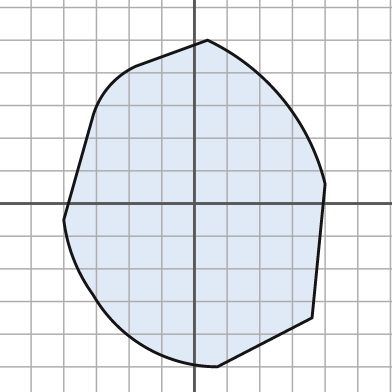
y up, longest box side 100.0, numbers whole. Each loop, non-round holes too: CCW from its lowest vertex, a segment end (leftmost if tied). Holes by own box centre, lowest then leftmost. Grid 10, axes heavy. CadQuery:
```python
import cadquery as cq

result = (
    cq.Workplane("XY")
    .moveTo(7.0, -50.0)
    .lineTo(36.0, -35.0)
    .lineTo(40.0, 6.0)
    .threePointArc((27.0, 32.0), (4.0, 50.0))
    .lineTo(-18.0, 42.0)
    .threePointArc((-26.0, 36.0), (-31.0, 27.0))
    .lineTo(-40.0, -5.0)
    .threePointArc((-37.0, -17.0), (-31.0, -28.0))
    .threePointArc((-15.0, -44.0), (7.0, -50.0))
    .close()
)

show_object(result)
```